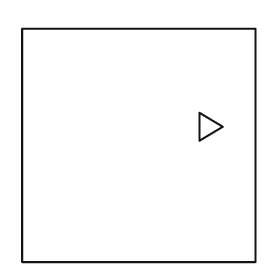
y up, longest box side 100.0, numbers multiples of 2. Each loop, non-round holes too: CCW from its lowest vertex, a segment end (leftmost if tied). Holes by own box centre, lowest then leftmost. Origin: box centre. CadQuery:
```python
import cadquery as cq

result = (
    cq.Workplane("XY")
    .moveTo(-50.0, -50.0)
    .lineTo(50.0, -50.0)
    .lineTo(50.0, 50.0)
    .lineTo(-50.0, 50.0)
    .close()
    .moveTo(26.0, 2.0)
    .lineTo(36.0, 8.0)
    .lineTo(26.0, 14.0)
    .close()
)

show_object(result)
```